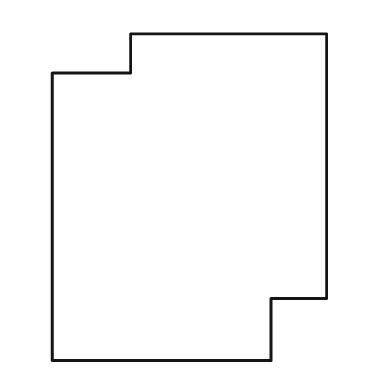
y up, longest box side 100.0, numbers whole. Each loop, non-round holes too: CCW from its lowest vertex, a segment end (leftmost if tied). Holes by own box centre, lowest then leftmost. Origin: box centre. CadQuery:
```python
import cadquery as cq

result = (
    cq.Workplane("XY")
    .moveTo(-42.0, -50.0)
    .lineTo(25.0, -50.0)
    .lineTo(25.0, -31.0)
    .lineTo(42.0, -31.0)
    .lineTo(42.0, 50.0)
    .lineTo(-18.0, 50.0)
    .lineTo(-18.0, 38.0)
    .lineTo(-42.0, 38.0)
    .close()
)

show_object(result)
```